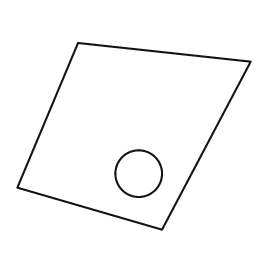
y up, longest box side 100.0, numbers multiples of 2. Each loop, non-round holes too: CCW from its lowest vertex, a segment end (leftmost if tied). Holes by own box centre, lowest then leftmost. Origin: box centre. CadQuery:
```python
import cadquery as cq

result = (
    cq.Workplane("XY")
    .moveTo(12.0, -40.0)
    .lineTo(50.0, 32.0)
    .lineTo(-24.0, 40.0)
    .lineTo(-50.0, -22.0)
    .close()
    .moveTo(2.0, -16.0)
    .circle(10.0)
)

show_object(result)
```